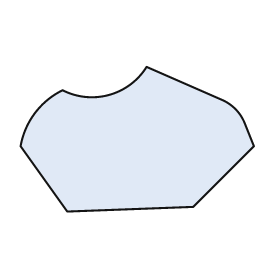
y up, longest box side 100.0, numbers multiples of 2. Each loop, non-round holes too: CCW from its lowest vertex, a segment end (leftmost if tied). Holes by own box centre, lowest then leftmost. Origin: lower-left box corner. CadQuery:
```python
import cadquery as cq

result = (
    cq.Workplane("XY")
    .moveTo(20.0, 0.0)
    .lineTo(74.0, 2.0)
    .lineTo(100.0, 28.0)
    .lineTo(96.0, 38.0)
    .threePointArc((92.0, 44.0), (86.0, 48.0))
    .lineTo(54.0, 62.0)
    .threePointArc((38.0, 50.0), (18.0, 52.0))
    .threePointArc((6.0, 42.0), (0.0, 28.0))
    .close()
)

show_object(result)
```